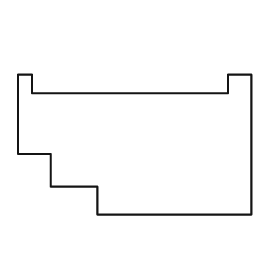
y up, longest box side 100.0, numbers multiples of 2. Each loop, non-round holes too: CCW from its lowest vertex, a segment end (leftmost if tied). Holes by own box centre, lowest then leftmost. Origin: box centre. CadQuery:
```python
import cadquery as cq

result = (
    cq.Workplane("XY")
    .moveTo(-16.0, -30.0)
    .lineTo(50.0, -30.0)
    .lineTo(50.0, 30.0)
    .lineTo(40.0, 30.0)
    .lineTo(40.0, 22.0)
    .lineTo(-44.0, 22.0)
    .lineTo(-44.0, 30.0)
    .lineTo(-50.0, 30.0)
    .lineTo(-50.0, -4.0)
    .lineTo(-36.0, -4.0)
    .lineTo(-36.0, -18.0)
    .lineTo(-16.0, -18.0)
    .close()
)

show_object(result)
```